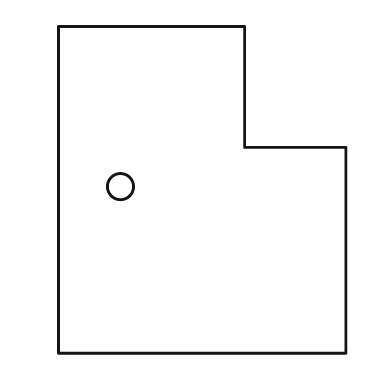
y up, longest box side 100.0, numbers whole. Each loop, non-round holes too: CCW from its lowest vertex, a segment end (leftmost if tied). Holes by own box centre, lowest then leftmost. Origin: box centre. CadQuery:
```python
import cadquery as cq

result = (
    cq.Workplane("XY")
    .moveTo(-44.0, -50.0)
    .lineTo(44.0, -50.0)
    .lineTo(44.0, 13.0)
    .lineTo(13.0, 13.0)
    .lineTo(13.0, 50.0)
    .lineTo(-44.0, 50.0)
    .close()
    .moveTo(-25.0, 1.0)
    .circle(4.0)
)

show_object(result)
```